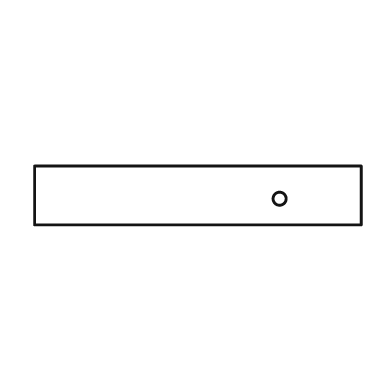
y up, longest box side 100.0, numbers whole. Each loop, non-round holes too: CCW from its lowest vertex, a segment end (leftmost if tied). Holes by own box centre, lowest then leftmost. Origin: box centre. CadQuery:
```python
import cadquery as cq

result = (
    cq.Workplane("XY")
    .moveTo(-50.0, -9.0)
    .lineTo(50.0, -9.0)
    .lineTo(50.0, 9.0)
    .lineTo(-50.0, 9.0)
    .close()
    .moveTo(25.0, -1.0)
    .circle(2.0)
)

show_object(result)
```